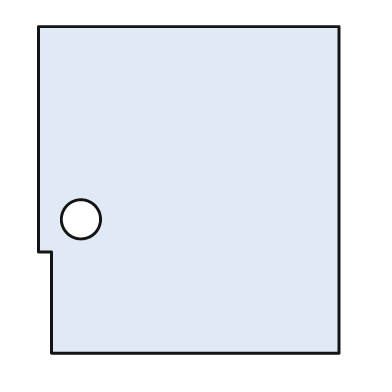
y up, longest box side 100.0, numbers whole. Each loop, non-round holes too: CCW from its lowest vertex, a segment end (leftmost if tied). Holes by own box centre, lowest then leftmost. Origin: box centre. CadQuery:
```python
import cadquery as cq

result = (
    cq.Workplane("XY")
    .moveTo(-42.0, -50.0)
    .lineTo(46.0, -50.0)
    .lineTo(46.0, 50.0)
    .lineTo(-46.0, 50.0)
    .lineTo(-46.0, -19.0)
    .lineTo(-42.0, -19.0)
    .close()
    .moveTo(-33.0, -9.0)
    .circle(6.0)
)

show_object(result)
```